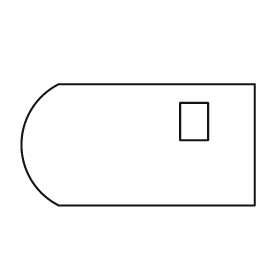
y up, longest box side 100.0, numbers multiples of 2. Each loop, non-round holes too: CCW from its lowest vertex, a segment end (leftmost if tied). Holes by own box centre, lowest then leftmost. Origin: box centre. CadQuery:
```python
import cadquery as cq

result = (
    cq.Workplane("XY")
    .moveTo(-34.0, -26.0)
    .lineTo(50.0, -26.0)
    .lineTo(50.0, 26.0)
    .lineTo(-34.0, 26.0)
    .threePointArc((-50.0, 0.0), (-34.0, -26.0))
    .close()
    .moveTo(18.0, 2.0)
    .lineTo(30.0, 2.0)
    .lineTo(30.0, 18.0)
    .lineTo(18.0, 18.0)
    .close()
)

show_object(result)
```